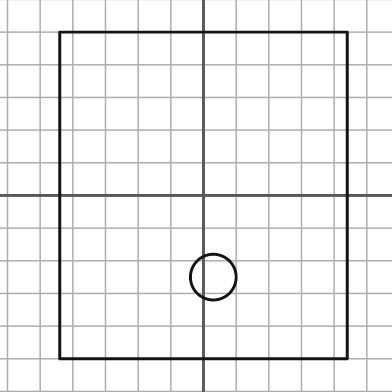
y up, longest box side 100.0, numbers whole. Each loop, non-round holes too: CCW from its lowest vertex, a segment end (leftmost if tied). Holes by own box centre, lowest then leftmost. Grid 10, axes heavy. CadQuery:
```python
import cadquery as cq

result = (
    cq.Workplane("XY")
    .moveTo(-44.0, -50.0)
    .lineTo(44.0, -50.0)
    .lineTo(44.0, 50.0)
    .lineTo(-44.0, 50.0)
    .close()
    .moveTo(3.0, -25.0)
    .circle(7.0)
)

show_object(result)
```